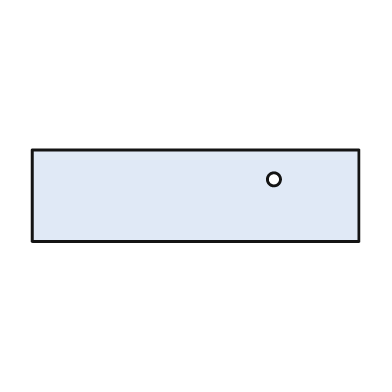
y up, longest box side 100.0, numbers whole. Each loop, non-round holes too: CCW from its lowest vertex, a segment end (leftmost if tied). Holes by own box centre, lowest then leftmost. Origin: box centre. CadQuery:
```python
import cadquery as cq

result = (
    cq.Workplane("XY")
    .moveTo(-50.0, -14.0)
    .lineTo(50.0, -14.0)
    .lineTo(50.0, 14.0)
    .lineTo(-50.0, 14.0)
    .close()
    .moveTo(24.0, 5.0)
    .circle(2.0)
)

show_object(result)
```